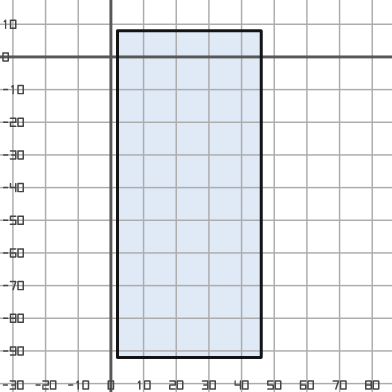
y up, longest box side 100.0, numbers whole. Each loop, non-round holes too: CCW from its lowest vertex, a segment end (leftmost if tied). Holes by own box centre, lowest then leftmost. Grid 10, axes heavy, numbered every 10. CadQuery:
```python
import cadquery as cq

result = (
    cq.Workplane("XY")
    .moveTo(2.0, -92.0)
    .lineTo(46.0, -92.0)
    .lineTo(46.0, 8.0)
    .lineTo(2.0, 8.0)
    .close()
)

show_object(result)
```